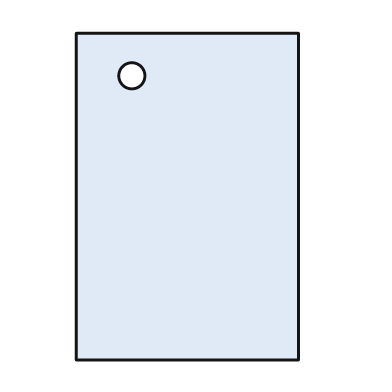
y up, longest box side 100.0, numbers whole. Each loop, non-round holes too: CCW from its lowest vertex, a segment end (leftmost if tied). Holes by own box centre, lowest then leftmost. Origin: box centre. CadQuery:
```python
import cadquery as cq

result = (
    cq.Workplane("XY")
    .moveTo(-34.0, -50.0)
    .lineTo(34.0, -50.0)
    .lineTo(34.0, 50.0)
    .lineTo(-34.0, 50.0)
    .close()
    .moveTo(-17.0, 37.0)
    .circle(4.0)
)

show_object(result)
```